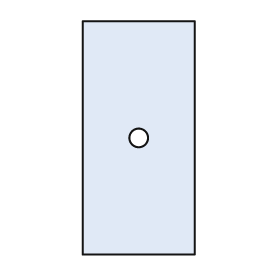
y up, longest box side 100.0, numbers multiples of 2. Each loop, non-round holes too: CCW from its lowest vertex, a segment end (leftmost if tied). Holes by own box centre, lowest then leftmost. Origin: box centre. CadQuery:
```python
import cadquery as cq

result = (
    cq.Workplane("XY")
    .moveTo(-24.0, -50.0)
    .lineTo(24.0, -50.0)
    .lineTo(24.0, 50.0)
    .lineTo(-24.0, 50.0)
    .close()
    .moveTo(0.0, 0.0)
    .circle(4.0)
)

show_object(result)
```